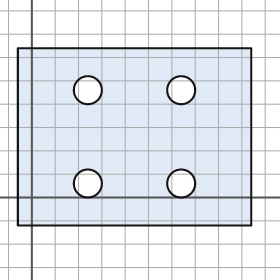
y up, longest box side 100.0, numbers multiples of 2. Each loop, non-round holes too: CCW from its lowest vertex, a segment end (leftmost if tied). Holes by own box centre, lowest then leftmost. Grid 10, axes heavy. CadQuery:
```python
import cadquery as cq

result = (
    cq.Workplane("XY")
    .moveTo(-6.0, -12.0)
    .lineTo(94.0, -12.0)
    .lineTo(94.0, 64.0)
    .lineTo(-6.0, 64.0)
    .close()
    .moveTo(24.0, 6.0)
    .circle(6.0)
    .moveTo(64.0, 6.0)
    .circle(6.0)
    .moveTo(24.0, 46.0)
    .circle(6.0)
    .moveTo(64.0, 46.0)
    .circle(6.0)
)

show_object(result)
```